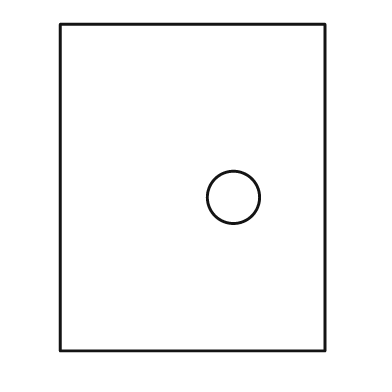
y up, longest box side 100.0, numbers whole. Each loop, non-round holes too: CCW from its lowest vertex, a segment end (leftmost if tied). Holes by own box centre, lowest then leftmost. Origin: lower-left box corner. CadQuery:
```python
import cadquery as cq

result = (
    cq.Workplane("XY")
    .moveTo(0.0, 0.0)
    .lineTo(81.0, 0.0)
    .lineTo(81.0, 100.0)
    .lineTo(0.0, 100.0)
    .close()
    .moveTo(53.0, 47.0)
    .circle(8.0)
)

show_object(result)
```